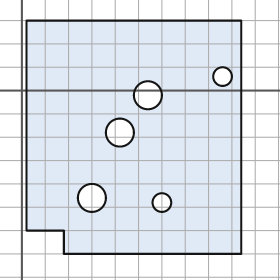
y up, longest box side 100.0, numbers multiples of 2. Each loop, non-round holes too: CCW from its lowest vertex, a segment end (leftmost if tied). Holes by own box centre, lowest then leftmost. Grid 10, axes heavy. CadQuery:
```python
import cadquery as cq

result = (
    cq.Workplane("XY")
    .moveTo(18.0, -70.0)
    .lineTo(94.0, -70.0)
    .lineTo(94.0, 30.0)
    .lineTo(2.0, 30.0)
    .lineTo(2.0, -60.0)
    .lineTo(18.0, -60.0)
    .close()
    .moveTo(60.0, -48.0)
    .circle(4.0)
    .moveTo(30.0, -46.0)
    .circle(6.0)
    .moveTo(42.0, -18.0)
    .circle(6.0)
    .moveTo(54.0, -2.0)
    .circle(6.0)
    .moveTo(86.0, 6.0)
    .circle(4.0)
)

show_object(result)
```